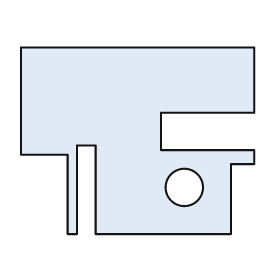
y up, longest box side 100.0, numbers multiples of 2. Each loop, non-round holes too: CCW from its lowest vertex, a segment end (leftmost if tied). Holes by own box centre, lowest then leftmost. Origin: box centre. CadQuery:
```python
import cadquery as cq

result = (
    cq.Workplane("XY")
    .moveTo(-30.0, -40.0)
    .lineTo(-26.0, -40.0)
    .lineTo(-26.0, -2.0)
    .lineTo(-18.0, -2.0)
    .lineTo(-18.0, -40.0)
    .lineTo(40.0, -40.0)
    .lineTo(40.0, -10.0)
    .lineTo(50.0, -10.0)
    .lineTo(50.0, -4.0)
    .lineTo(10.0, -4.0)
    .lineTo(10.0, 12.0)
    .lineTo(50.0, 12.0)
    .lineTo(50.0, 40.0)
    .lineTo(-50.0, 40.0)
    .lineTo(-50.0, -6.0)
    .lineTo(-30.0, -6.0)
    .close()
    .moveTo(20.0, -20.0)
    .circle(8.0)
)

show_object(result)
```